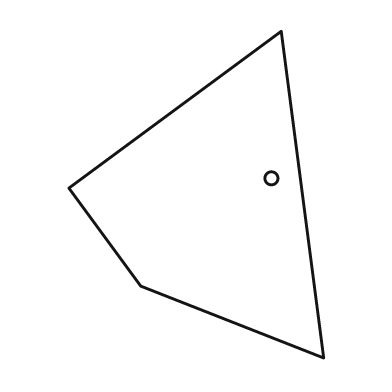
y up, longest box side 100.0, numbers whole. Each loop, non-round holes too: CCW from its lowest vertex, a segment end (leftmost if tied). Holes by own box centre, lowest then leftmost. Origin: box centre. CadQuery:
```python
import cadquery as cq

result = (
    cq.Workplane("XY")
    .moveTo(39.0, -50.0)
    .lineTo(26.0, 50.0)
    .lineTo(-39.0, 2.0)
    .lineTo(-17.0, -28.0)
    .close()
    .moveTo(23.0, 5.0)
    .circle(2.0)
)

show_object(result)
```